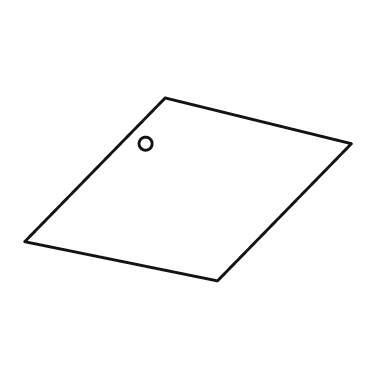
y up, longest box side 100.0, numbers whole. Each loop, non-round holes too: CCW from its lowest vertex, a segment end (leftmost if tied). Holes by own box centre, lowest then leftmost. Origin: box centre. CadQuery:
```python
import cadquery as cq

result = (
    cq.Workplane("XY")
    .moveTo(9.0, -28.0)
    .lineTo(50.0, 14.0)
    .lineTo(-7.0, 28.0)
    .lineTo(-50.0, -16.0)
    .close()
    .moveTo(-13.0, 14.0)
    .circle(2.0)
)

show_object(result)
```